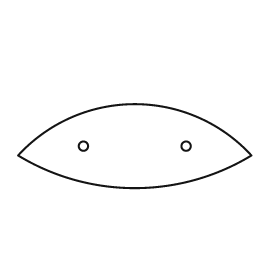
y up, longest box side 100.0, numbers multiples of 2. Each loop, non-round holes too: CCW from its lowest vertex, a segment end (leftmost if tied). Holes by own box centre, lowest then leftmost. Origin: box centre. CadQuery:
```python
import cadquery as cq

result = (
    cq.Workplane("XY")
    .moveTo(-50.0, -4.0)
    .threePointArc((0.0, -18.0), (50.0, -4.0))
    .threePointArc((0.0, 18.0), (-50.0, -4.0))
    .close()
    .moveTo(-22.0, 0.0)
    .circle(2.0)
    .moveTo(22.0, 0.0)
    .circle(2.0)
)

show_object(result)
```